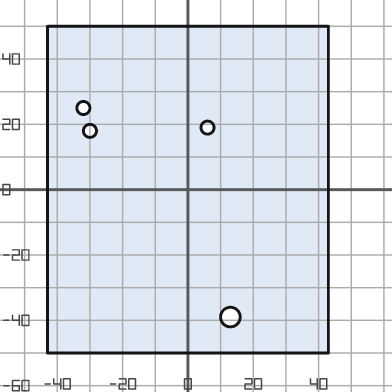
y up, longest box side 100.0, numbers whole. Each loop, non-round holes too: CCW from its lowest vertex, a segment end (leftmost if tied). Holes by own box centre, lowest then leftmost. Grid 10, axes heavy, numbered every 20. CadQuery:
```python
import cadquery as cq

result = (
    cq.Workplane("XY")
    .moveTo(-43.0, -50.0)
    .lineTo(43.0, -50.0)
    .lineTo(43.0, 50.0)
    .lineTo(-43.0, 50.0)
    .close()
    .moveTo(13.0, -39.0)
    .circle(3.0)
    .moveTo(-30.0, 18.0)
    .circle(2.0)
    .moveTo(6.0, 19.0)
    .circle(2.0)
    .moveTo(-32.0, 25.0)
    .circle(2.0)
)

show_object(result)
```